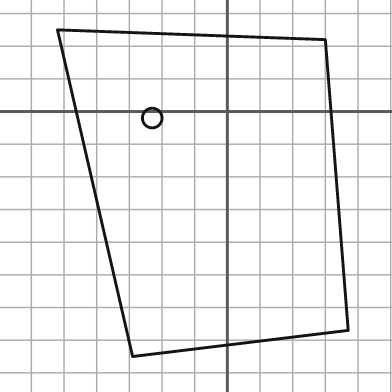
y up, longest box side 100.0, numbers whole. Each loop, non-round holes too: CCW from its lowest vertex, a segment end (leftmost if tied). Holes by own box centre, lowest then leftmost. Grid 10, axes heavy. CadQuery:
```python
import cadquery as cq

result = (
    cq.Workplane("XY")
    .moveTo(-29.0, -75.0)
    .lineTo(37.0, -67.0)
    .lineTo(30.0, 22.0)
    .lineTo(-52.0, 25.0)
    .close()
    .moveTo(-23.0, -2.0)
    .circle(3.0)
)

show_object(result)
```